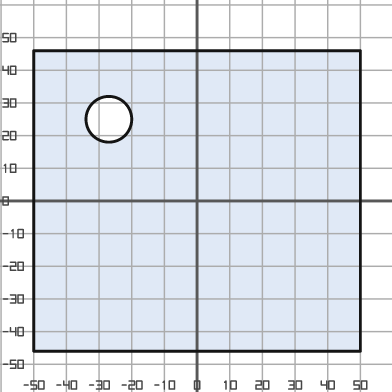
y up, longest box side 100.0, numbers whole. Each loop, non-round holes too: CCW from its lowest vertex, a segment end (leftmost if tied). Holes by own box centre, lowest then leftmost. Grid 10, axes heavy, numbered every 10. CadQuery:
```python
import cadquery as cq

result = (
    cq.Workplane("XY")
    .moveTo(-50.0, -46.0)
    .lineTo(50.0, -46.0)
    .lineTo(50.0, 46.0)
    .lineTo(-50.0, 46.0)
    .close()
    .moveTo(-27.0, 25.0)
    .circle(7.0)
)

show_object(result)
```